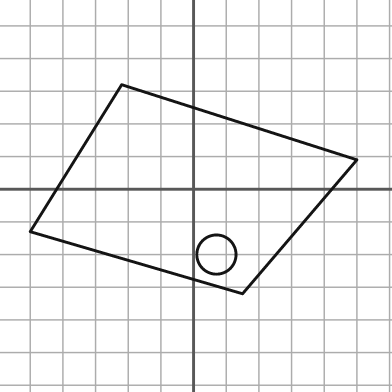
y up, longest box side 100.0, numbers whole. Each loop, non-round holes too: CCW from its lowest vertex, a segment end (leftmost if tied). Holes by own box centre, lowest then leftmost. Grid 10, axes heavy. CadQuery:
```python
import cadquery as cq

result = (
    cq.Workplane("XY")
    .moveTo(15.0, -32.0)
    .lineTo(50.0, 9.0)
    .lineTo(-22.0, 32.0)
    .lineTo(-50.0, -13.0)
    .close()
    .moveTo(7.0, -20.0)
    .circle(6.0)
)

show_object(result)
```